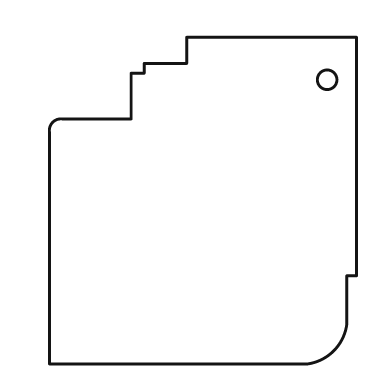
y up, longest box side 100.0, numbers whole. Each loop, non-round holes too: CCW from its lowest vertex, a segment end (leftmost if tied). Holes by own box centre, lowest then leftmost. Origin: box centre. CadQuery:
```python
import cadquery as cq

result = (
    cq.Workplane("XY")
    .moveTo(-47.0, -50.0)
    .lineTo(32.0, -50.0)
    .threePointArc((40.0, -46.0), (44.0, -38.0))
    .lineTo(44.0, -23.0)
    .lineTo(47.0, -23.0)
    .lineTo(47.0, 50.0)
    .lineTo(-5.0, 50.0)
    .lineTo(-5.0, 42.0)
    .lineTo(-18.0, 42.0)
    .lineTo(-18.0, 39.0)
    .lineTo(-22.0, 39.0)
    .lineTo(-22.0, 25.0)
    .lineTo(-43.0, 25.0)
    .threePointArc((-46.0, 24.0), (-47.0, 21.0))
    .close()
    .moveTo(38.0, 37.0)
    .circle(3.0)
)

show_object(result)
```